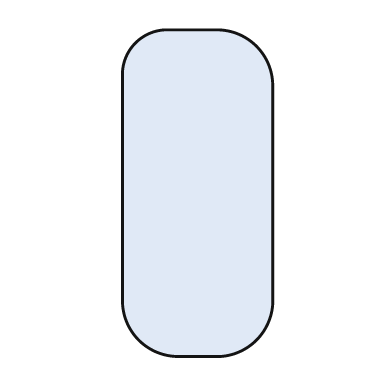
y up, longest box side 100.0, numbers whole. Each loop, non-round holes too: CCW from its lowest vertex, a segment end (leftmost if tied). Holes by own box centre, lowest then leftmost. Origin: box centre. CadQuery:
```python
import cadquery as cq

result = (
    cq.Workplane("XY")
    .moveTo(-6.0, -50.0)
    .lineTo(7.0, -50.0)
    .threePointArc((18.0, -45.0), (23.0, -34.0))
    .lineTo(23.0, 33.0)
    .threePointArc((18.0, 45.0), (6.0, 50.0))
    .lineTo(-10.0, 50.0)
    .threePointArc((-19.0, 46.0), (-23.0, 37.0))
    .lineTo(-23.0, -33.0)
    .threePointArc((-18.0, -45.0), (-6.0, -50.0))
    .close()
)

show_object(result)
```